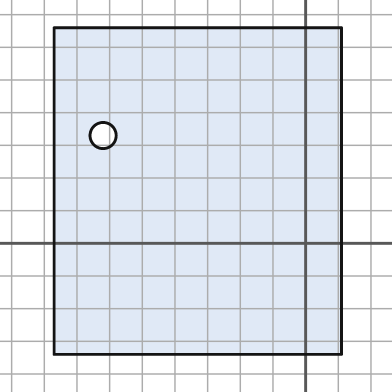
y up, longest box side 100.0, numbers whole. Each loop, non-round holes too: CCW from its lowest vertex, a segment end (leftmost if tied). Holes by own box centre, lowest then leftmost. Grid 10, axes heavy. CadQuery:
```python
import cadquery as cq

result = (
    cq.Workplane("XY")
    .moveTo(-77.0, -34.0)
    .lineTo(11.0, -34.0)
    .lineTo(11.0, 66.0)
    .lineTo(-77.0, 66.0)
    .close()
    .moveTo(-62.0, 33.0)
    .circle(4.0)
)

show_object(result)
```